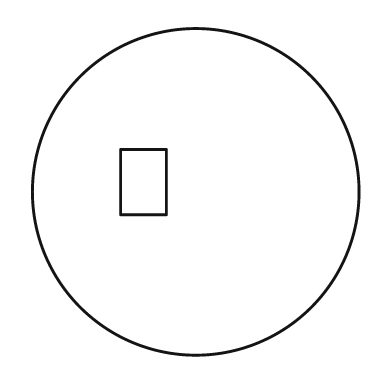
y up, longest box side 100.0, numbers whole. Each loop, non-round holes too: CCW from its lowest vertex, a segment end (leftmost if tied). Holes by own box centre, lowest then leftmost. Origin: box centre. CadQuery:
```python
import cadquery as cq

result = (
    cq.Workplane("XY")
    .moveTo(0.0, 0.0)
    .circle(50.0)
    .moveTo(-23.0, -7.0)
    .lineTo(-9.0, -7.0)
    .lineTo(-9.0, 13.0)
    .lineTo(-23.0, 13.0)
    .close()
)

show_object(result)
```